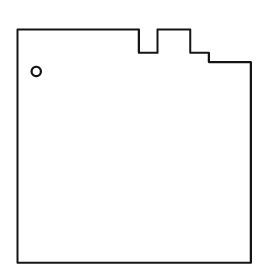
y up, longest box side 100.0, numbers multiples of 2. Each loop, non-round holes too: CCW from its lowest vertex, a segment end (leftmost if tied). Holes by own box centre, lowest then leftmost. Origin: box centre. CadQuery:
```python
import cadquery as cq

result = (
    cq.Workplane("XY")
    .moveTo(-50.0, -50.0)
    .lineTo(50.0, -50.0)
    .lineTo(50.0, 36.0)
    .lineTo(32.0, 36.0)
    .lineTo(32.0, 40.0)
    .lineTo(24.0, 40.0)
    .lineTo(24.0, 50.0)
    .lineTo(10.0, 50.0)
    .lineTo(10.0, 40.0)
    .lineTo(2.0, 40.0)
    .lineTo(2.0, 50.0)
    .lineTo(-50.0, 50.0)
    .close()
    .moveTo(-42.0, 32.0)
    .circle(2.0)
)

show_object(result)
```